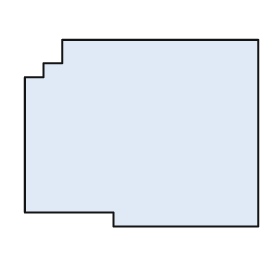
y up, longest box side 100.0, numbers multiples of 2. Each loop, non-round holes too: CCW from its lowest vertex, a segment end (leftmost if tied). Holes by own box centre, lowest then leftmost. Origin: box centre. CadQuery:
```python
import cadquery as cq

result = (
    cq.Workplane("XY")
    .moveTo(-12.0, -40.0)
    .lineTo(50.0, -40.0)
    .lineTo(50.0, 40.0)
    .lineTo(-34.0, 40.0)
    .lineTo(-34.0, 30.0)
    .lineTo(-42.0, 30.0)
    .lineTo(-42.0, 24.0)
    .lineTo(-50.0, 24.0)
    .lineTo(-50.0, -34.0)
    .lineTo(-12.0, -34.0)
    .close()
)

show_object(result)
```